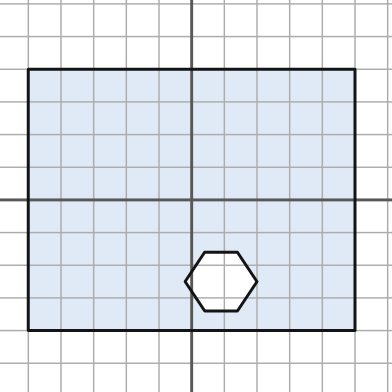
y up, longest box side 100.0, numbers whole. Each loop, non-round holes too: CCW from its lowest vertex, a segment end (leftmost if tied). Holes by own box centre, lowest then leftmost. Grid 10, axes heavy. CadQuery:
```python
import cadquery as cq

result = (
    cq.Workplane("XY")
    .moveTo(-50.0, -40.0)
    .lineTo(50.0, -40.0)
    .lineTo(50.0, 40.0)
    .lineTo(-50.0, 40.0)
    .close()
    .moveTo(4.0, -34.0)
    .lineTo(14.0, -34.0)
    .lineTo(20.0, -25.0)
    .lineTo(14.0, -16.0)
    .lineTo(4.0, -16.0)
    .lineTo(-2.0, -25.0)
    .close()
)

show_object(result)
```